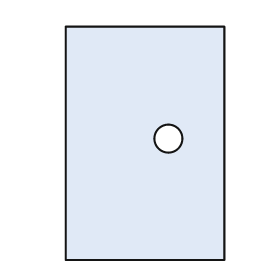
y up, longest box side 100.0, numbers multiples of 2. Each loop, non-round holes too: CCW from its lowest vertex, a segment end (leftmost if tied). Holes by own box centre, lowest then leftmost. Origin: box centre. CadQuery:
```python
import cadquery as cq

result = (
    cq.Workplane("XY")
    .moveTo(-34.0, -50.0)
    .lineTo(34.0, -50.0)
    .lineTo(34.0, 50.0)
    .lineTo(-34.0, 50.0)
    .close()
    .moveTo(10.0, 2.0)
    .circle(6.0)
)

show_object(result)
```